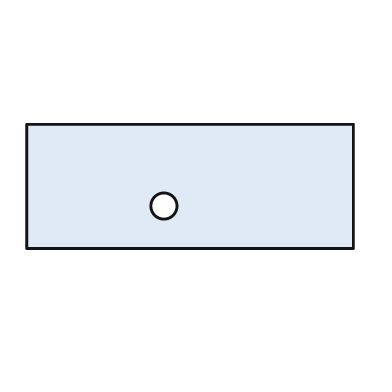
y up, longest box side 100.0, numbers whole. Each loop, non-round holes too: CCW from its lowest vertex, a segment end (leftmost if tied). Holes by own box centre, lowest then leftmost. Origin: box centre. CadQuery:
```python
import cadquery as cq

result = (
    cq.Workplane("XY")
    .moveTo(-50.0, -19.0)
    .lineTo(50.0, -19.0)
    .lineTo(50.0, 19.0)
    .lineTo(-50.0, 19.0)
    .close()
    .moveTo(-8.0, -6.0)
    .circle(4.0)
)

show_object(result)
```